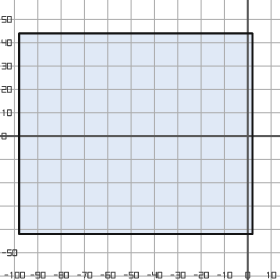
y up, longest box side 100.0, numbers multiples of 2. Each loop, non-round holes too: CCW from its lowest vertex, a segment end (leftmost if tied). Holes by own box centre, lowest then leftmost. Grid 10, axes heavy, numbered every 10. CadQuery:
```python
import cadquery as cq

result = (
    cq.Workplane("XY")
    .moveTo(-98.0, -42.0)
    .lineTo(2.0, -42.0)
    .lineTo(2.0, 44.0)
    .lineTo(-98.0, 44.0)
    .close()
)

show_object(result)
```